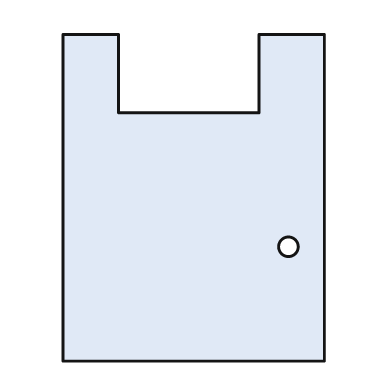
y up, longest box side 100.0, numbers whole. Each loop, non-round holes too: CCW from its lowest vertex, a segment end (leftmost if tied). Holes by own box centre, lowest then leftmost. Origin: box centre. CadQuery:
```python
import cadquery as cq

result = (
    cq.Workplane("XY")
    .moveTo(-40.0, -50.0)
    .lineTo(40.0, -50.0)
    .lineTo(40.0, 50.0)
    .lineTo(20.0, 50.0)
    .lineTo(20.0, 26.0)
    .lineTo(-23.0, 26.0)
    .lineTo(-23.0, 50.0)
    .lineTo(-40.0, 50.0)
    .close()
    .moveTo(29.0, -15.0)
    .circle(3.0)
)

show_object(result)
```